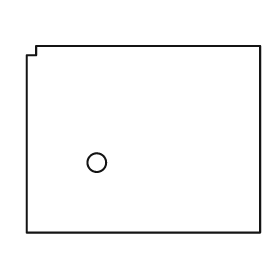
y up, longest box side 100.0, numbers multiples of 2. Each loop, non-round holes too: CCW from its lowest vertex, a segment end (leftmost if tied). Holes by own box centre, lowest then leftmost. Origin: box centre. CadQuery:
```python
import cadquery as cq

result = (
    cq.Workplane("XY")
    .moveTo(-50.0, -40.0)
    .lineTo(50.0, -40.0)
    .lineTo(50.0, 40.0)
    .lineTo(-46.0, 40.0)
    .lineTo(-46.0, 36.0)
    .lineTo(-50.0, 36.0)
    .close()
    .moveTo(-20.0, -10.0)
    .circle(4.0)
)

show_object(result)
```